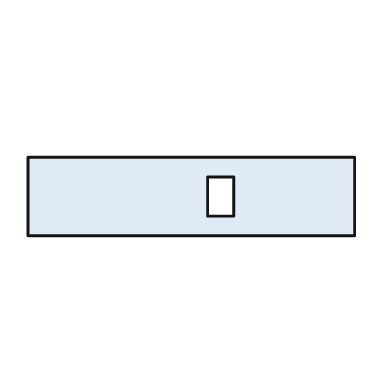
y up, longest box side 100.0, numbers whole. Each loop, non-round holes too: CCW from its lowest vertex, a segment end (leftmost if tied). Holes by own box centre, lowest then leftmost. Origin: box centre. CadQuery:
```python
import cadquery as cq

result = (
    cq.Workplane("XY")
    .moveTo(-50.0, -12.0)
    .lineTo(50.0, -12.0)
    .lineTo(50.0, 12.0)
    .lineTo(-50.0, 12.0)
    .close()
    .moveTo(5.0, -6.0)
    .lineTo(13.0, -6.0)
    .lineTo(13.0, 6.0)
    .lineTo(5.0, 6.0)
    .close()
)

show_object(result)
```